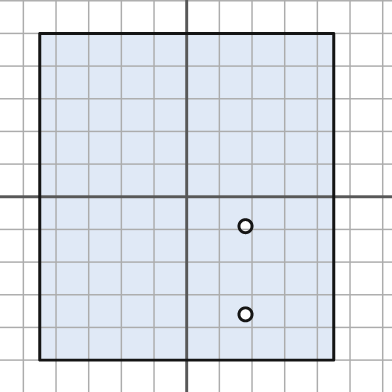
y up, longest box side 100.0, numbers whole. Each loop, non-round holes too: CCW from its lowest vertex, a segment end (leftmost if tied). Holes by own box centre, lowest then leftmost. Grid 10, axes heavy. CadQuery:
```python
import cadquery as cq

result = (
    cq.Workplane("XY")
    .moveTo(-45.0, -50.0)
    .lineTo(45.0, -50.0)
    .lineTo(45.0, 50.0)
    .lineTo(-45.0, 50.0)
    .close()
    .moveTo(18.0, -36.0)
    .circle(2.0)
    .moveTo(18.0, -9.0)
    .circle(2.0)
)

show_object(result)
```